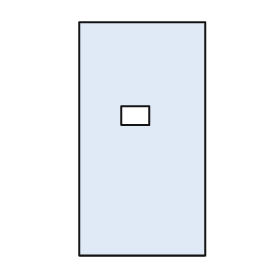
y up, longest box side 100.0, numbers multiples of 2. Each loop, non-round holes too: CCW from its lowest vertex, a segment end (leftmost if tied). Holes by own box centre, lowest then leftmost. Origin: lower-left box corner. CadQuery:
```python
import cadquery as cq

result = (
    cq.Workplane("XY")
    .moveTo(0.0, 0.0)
    .lineTo(54.0, 0.0)
    .lineTo(54.0, 100.0)
    .lineTo(0.0, 100.0)
    .close()
    .moveTo(18.0, 56.0)
    .lineTo(30.0, 56.0)
    .lineTo(30.0, 64.0)
    .lineTo(18.0, 64.0)
    .close()
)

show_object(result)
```